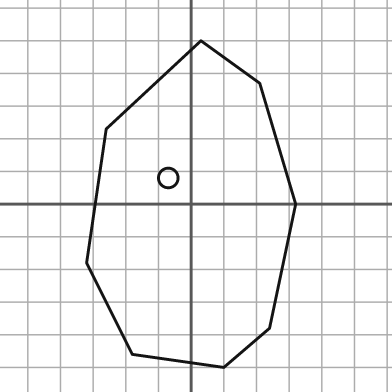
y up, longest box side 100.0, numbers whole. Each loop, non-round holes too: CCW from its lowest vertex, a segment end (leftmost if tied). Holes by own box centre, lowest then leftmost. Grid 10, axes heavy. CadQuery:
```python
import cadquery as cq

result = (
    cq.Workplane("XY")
    .moveTo(10.0, -50.0)
    .lineTo(24.0, -38.0)
    .lineTo(32.0, 0.0)
    .lineTo(21.0, 37.0)
    .lineTo(3.0, 50.0)
    .lineTo(-26.0, 23.0)
    .lineTo(-32.0, -18.0)
    .lineTo(-18.0, -46.0)
    .close()
    .moveTo(-7.0, 8.0)
    .circle(3.0)
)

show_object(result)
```